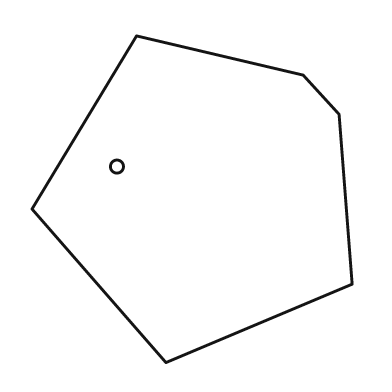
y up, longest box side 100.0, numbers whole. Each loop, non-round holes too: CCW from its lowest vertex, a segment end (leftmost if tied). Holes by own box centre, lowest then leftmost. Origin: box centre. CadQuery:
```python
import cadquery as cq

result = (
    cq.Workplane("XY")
    .moveTo(-8.0, -50.0)
    .lineTo(49.0, -26.0)
    .lineTo(45.0, 26.0)
    .lineTo(34.0, 38.0)
    .lineTo(-17.0, 50.0)
    .lineTo(-49.0, -3.0)
    .close()
    .moveTo(-23.0, 10.0)
    .circle(2.0)
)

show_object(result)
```